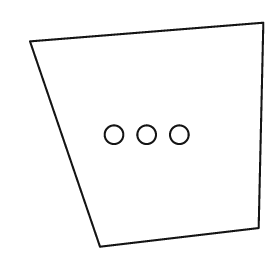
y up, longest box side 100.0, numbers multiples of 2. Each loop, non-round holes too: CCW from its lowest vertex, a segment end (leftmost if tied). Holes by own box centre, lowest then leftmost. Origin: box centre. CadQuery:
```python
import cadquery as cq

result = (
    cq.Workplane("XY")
    .moveTo(-20.0, -48.0)
    .lineTo(48.0, -40.0)
    .lineTo(50.0, 48.0)
    .lineTo(-50.0, 40.0)
    .close()
    .moveTo(-14.0, 0.0)
    .circle(4.0)
    .moveTo(0.0, 0.0)
    .circle(4.0)
    .moveTo(14.0, 0.0)
    .circle(4.0)
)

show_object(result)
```